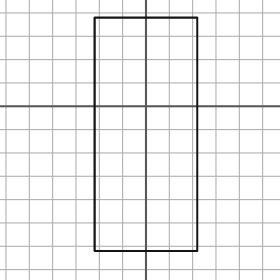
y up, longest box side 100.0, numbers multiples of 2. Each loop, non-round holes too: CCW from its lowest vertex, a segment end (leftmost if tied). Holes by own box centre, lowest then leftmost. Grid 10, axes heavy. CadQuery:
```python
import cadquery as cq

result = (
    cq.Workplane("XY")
    .moveTo(-22.0, -62.0)
    .lineTo(22.0, -62.0)
    .lineTo(22.0, 38.0)
    .lineTo(-22.0, 38.0)
    .close()
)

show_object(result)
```